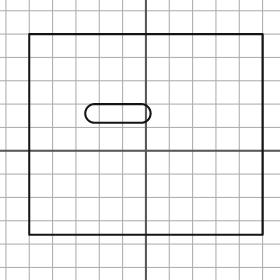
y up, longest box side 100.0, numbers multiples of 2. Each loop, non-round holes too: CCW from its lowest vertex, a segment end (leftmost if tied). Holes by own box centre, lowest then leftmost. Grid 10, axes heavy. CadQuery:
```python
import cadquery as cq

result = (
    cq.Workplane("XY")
    .moveTo(-50.0, -36.0)
    .lineTo(50.0, -36.0)
    .lineTo(50.0, 50.0)
    .lineTo(-50.0, 50.0)
    .close()
    .moveTo(-22.0, 12.0)
    .lineTo(-2.0, 12.0)
    .threePointArc((2.0, 16.0), (-2.0, 20.0))
    .lineTo(-22.0, 20.0)
    .threePointArc((-26.0, 16.0), (-22.0, 12.0))
    .close()
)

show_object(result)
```